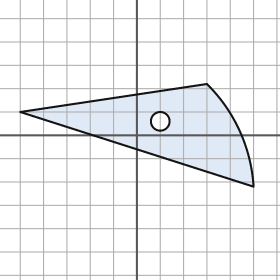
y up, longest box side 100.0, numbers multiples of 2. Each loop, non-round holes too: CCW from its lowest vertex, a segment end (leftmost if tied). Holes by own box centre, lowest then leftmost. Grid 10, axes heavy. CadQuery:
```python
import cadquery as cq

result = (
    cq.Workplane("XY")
    .moveTo(50.0, -22.0)
    .threePointArc((44.0, 2.0), (30.0, 22.0))
    .lineTo(-50.0, 10.0)
    .close()
    .moveTo(10.0, 6.0)
    .circle(4.0)
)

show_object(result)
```